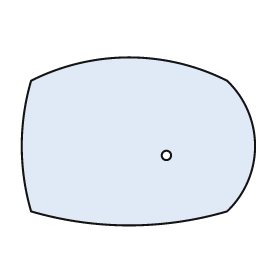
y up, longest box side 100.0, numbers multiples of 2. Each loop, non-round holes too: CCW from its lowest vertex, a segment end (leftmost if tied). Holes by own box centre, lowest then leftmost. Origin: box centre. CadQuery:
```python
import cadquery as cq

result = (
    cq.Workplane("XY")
    .moveTo(-46.0, -30.0)
    .threePointArc((-4.0, -36.0), (38.0, -30.0))
    .threePointArc((50.0, -2.0), (38.0, 26.0))
    .threePointArc((-4.0, 36.0), (-46.0, 26.0))
    .threePointArc((-50.0, -2.0), (-46.0, -30.0))
    .close()
    .moveTo(12.0, -6.0)
    .circle(2.0)
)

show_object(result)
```